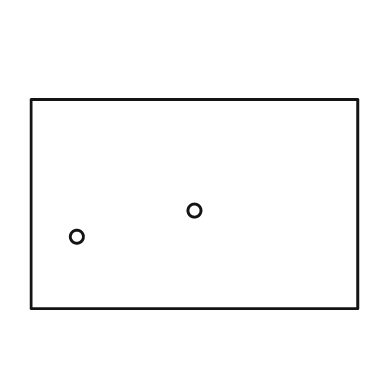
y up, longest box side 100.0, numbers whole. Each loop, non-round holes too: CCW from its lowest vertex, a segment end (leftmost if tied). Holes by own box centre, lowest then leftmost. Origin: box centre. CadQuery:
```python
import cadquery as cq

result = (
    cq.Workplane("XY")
    .moveTo(-50.0, -32.0)
    .lineTo(50.0, -32.0)
    .lineTo(50.0, 32.0)
    .lineTo(-50.0, 32.0)
    .close()
    .moveTo(-36.0, -10.0)
    .circle(2.0)
    .moveTo(0.0, -2.0)
    .circle(2.0)
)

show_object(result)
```